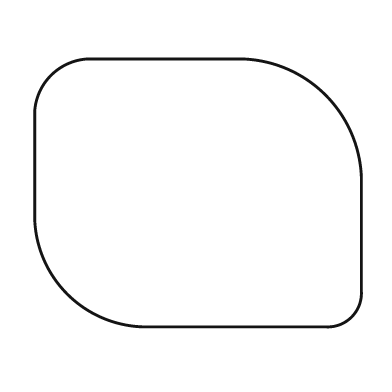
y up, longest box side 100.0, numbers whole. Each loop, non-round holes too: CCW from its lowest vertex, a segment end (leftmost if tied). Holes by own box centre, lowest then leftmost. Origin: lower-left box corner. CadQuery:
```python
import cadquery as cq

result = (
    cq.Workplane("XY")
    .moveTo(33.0, 0.0)
    .lineTo(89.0, 0.0)
    .threePointArc((97.0, 3.0), (100.0, 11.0))
    .lineTo(100.0, 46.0)
    .threePointArc((89.0, 71.0), (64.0, 82.0))
    .lineTo(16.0, 82.0)
    .threePointArc((5.0, 77.0), (0.0, 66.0))
    .lineTo(0.0, 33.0)
    .threePointArc((10.0, 10.0), (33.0, 0.0))
    .close()
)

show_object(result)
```